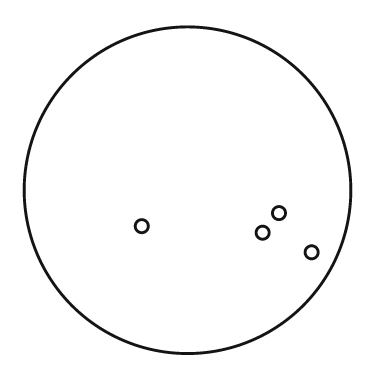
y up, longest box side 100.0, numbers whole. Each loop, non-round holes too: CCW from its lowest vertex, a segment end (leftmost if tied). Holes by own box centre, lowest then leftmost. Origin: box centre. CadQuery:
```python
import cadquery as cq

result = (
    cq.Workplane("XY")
    .moveTo(0.0, 0.0)
    .circle(50.0)
    .moveTo(38.0, -19.0)
    .circle(2.0)
    .moveTo(23.0, -13.0)
    .circle(2.0)
    .moveTo(-14.0, -11.0)
    .circle(2.0)
    .moveTo(28.0, -7.0)
    .circle(2.0)
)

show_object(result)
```